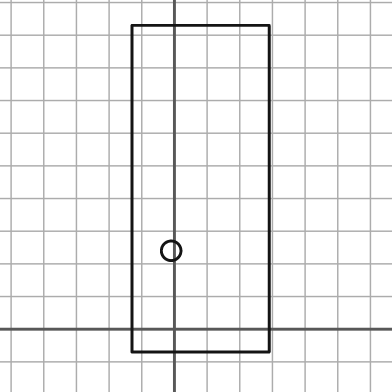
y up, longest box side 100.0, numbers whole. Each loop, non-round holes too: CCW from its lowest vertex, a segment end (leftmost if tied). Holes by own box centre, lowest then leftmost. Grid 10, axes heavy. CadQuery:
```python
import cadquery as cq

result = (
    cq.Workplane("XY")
    .moveTo(-13.0, -7.0)
    .lineTo(29.0, -7.0)
    .lineTo(29.0, 93.0)
    .lineTo(-13.0, 93.0)
    .close()
    .moveTo(-1.0, 24.0)
    .circle(3.0)
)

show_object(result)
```